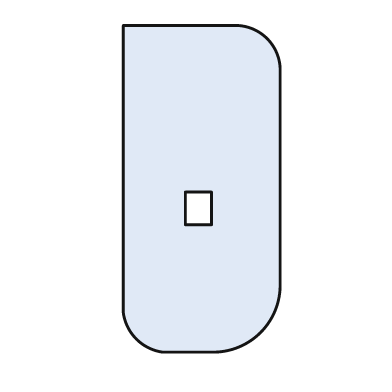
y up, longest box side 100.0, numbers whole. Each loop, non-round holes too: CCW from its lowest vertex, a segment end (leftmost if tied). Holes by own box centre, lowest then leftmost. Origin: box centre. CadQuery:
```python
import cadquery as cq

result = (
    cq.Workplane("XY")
    .moveTo(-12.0, -50.0)
    .lineTo(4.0, -50.0)
    .threePointArc((18.0, -44.0), (24.0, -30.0))
    .lineTo(24.0, 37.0)
    .threePointArc((20.0, 46.0), (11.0, 50.0))
    .lineTo(-24.0, 50.0)
    .lineTo(-24.0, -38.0)
    .threePointArc((-20.0, -46.0), (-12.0, -50.0))
    .close()
    .moveTo(-5.0, -11.0)
    .lineTo(3.0, -11.0)
    .lineTo(3.0, -1.0)
    .lineTo(-5.0, -1.0)
    .close()
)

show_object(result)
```